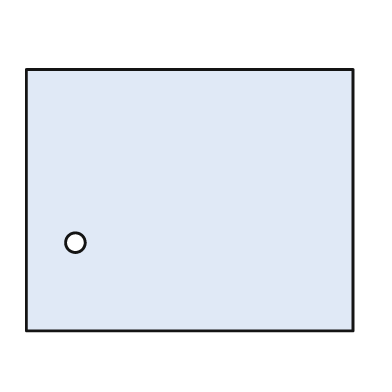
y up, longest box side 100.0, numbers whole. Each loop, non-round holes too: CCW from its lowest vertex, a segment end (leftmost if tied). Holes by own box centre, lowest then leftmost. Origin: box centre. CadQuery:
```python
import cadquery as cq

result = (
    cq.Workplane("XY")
    .moveTo(-50.0, -40.0)
    .lineTo(50.0, -40.0)
    .lineTo(50.0, 40.0)
    .lineTo(-50.0, 40.0)
    .close()
    .moveTo(-35.0, -13.0)
    .circle(3.0)
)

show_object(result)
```